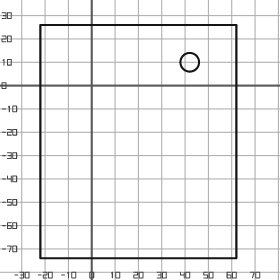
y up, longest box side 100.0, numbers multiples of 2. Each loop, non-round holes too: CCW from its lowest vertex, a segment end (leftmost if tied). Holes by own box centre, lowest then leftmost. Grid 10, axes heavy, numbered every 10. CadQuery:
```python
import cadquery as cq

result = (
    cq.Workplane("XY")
    .moveTo(-22.0, -74.0)
    .lineTo(62.0, -74.0)
    .lineTo(62.0, 26.0)
    .lineTo(-22.0, 26.0)
    .close()
    .moveTo(42.0, 10.0)
    .circle(4.0)
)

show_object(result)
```